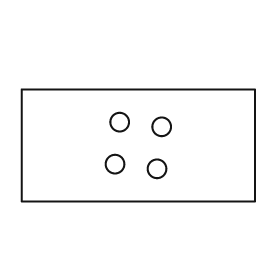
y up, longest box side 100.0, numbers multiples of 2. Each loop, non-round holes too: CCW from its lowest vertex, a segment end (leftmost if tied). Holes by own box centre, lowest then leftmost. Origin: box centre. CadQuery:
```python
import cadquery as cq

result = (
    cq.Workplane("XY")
    .moveTo(-50.0, -24.0)
    .lineTo(50.0, -24.0)
    .lineTo(50.0, 24.0)
    .lineTo(-50.0, 24.0)
    .close()
    .moveTo(8.0, -10.0)
    .circle(4.0)
    .moveTo(-10.0, -8.0)
    .circle(4.0)
    .moveTo(10.0, 8.0)
    .circle(4.0)
    .moveTo(-8.0, 10.0)
    .circle(4.0)
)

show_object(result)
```